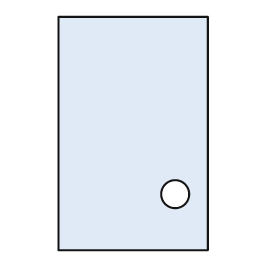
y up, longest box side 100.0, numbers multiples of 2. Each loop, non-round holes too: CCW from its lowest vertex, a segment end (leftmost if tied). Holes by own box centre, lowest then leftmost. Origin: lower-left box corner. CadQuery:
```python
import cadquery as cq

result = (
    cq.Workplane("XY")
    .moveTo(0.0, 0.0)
    .lineTo(64.0, 0.0)
    .lineTo(64.0, 100.0)
    .lineTo(0.0, 100.0)
    .close()
    .moveTo(50.0, 24.0)
    .circle(6.0)
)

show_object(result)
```